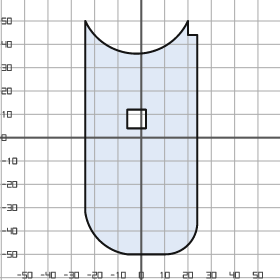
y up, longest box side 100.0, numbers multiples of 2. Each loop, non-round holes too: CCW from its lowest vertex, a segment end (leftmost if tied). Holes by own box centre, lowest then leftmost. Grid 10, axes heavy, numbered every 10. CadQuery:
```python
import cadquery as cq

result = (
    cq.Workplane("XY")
    .moveTo(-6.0, -50.0)
    .lineTo(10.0, -50.0)
    .threePointArc((20.0, -46.0), (24.0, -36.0))
    .lineTo(24.0, 44.0)
    .lineTo(20.0, 44.0)
    .lineTo(20.0, 50.0)
    .threePointArc((-2.0, 36.0), (-24.0, 50.0))
    .lineTo(-24.0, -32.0)
    .threePointArc((-18.0, -44.0), (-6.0, -50.0))
    .close()
    .moveTo(-6.0, 4.0)
    .lineTo(2.0, 4.0)
    .lineTo(2.0, 12.0)
    .lineTo(-6.0, 12.0)
    .close()
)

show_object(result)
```